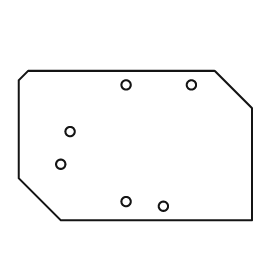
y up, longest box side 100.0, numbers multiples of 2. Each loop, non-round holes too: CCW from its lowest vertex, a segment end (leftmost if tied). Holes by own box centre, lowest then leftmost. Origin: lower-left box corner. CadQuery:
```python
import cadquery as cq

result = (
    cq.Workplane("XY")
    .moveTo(18.0, 0.0)
    .lineTo(100.0, 0.0)
    .lineTo(100.0, 48.0)
    .lineTo(84.0, 64.0)
    .lineTo(4.0, 64.0)
    .lineTo(0.0, 60.0)
    .lineTo(0.0, 18.0)
    .close()
    .moveTo(62.0, 6.0)
    .circle(2.0)
    .moveTo(46.0, 8.0)
    .circle(2.0)
    .moveTo(18.0, 24.0)
    .circle(2.0)
    .moveTo(22.0, 38.0)
    .circle(2.0)
    .moveTo(46.0, 58.0)
    .circle(2.0)
    .moveTo(74.0, 58.0)
    .circle(2.0)
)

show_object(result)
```